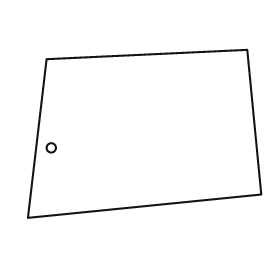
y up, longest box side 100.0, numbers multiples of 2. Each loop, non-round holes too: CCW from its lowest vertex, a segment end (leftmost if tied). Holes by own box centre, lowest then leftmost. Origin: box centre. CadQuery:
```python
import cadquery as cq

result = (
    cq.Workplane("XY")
    .moveTo(-50.0, -36.0)
    .lineTo(50.0, -26.0)
    .lineTo(44.0, 36.0)
    .lineTo(-42.0, 32.0)
    .close()
    .moveTo(-40.0, -6.0)
    .circle(2.0)
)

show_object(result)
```